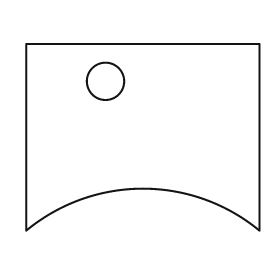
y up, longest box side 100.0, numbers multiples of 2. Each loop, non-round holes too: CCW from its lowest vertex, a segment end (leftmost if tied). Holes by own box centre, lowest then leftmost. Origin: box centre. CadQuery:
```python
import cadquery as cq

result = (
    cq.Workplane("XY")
    .moveTo(-50.0, -40.0)
    .threePointArc((0.0, -22.0), (50.0, -40.0))
    .lineTo(50.0, 40.0)
    .lineTo(-50.0, 40.0)
    .close()
    .moveTo(-16.0, 24.0)
    .circle(8.0)
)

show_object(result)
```